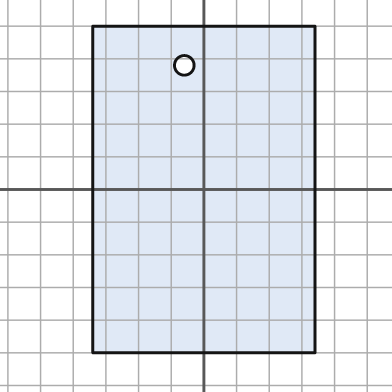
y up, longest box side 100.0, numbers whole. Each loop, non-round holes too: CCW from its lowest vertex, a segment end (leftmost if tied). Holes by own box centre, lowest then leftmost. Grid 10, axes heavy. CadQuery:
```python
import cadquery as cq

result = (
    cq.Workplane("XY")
    .moveTo(-34.0, -50.0)
    .lineTo(34.0, -50.0)
    .lineTo(34.0, 50.0)
    .lineTo(-34.0, 50.0)
    .close()
    .moveTo(-6.0, 38.0)
    .circle(3.0)
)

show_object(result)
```